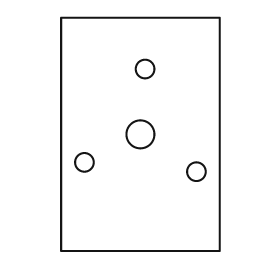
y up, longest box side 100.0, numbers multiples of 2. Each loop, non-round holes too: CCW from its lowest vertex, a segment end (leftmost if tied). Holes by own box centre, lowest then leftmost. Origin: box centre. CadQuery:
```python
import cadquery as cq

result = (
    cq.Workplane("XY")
    .moveTo(-34.0, -50.0)
    .lineTo(34.0, -50.0)
    .lineTo(34.0, 50.0)
    .lineTo(-34.0, 50.0)
    .close()
    .moveTo(24.0, -16.0)
    .circle(4.0)
    .moveTo(-24.0, -12.0)
    .circle(4.0)
    .moveTo(0.0, 0.0)
    .circle(6.0)
    .moveTo(2.0, 28.0)
    .circle(4.0)
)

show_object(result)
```